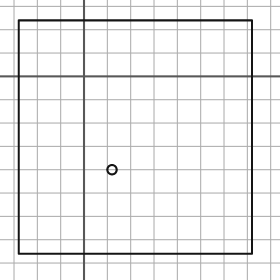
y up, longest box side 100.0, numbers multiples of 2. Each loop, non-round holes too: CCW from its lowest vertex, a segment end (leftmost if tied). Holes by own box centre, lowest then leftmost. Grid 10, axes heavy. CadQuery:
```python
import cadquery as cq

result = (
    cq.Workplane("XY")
    .moveTo(-28.0, -76.0)
    .lineTo(72.0, -76.0)
    .lineTo(72.0, 24.0)
    .lineTo(-28.0, 24.0)
    .close()
    .moveTo(12.0, -40.0)
    .circle(2.0)
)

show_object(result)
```